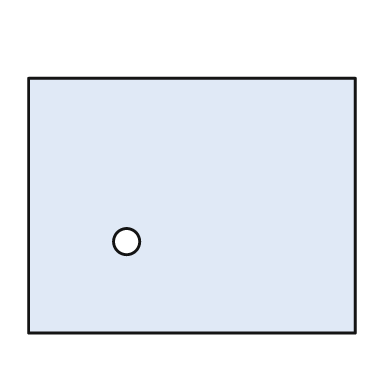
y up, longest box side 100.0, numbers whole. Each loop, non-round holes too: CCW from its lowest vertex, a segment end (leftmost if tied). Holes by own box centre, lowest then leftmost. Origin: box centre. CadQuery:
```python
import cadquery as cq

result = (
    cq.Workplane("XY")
    .moveTo(-50.0, -39.0)
    .lineTo(50.0, -39.0)
    .lineTo(50.0, 39.0)
    .lineTo(-50.0, 39.0)
    .close()
    .moveTo(-20.0, -11.0)
    .circle(4.0)
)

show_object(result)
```